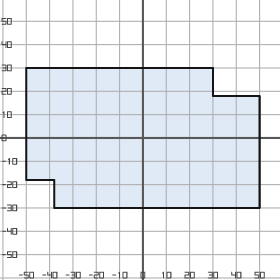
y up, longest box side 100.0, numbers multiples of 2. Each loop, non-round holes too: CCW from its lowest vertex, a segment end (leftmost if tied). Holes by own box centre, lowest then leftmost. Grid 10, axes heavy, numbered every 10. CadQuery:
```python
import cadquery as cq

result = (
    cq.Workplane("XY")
    .moveTo(-38.0, -30.0)
    .lineTo(50.0, -30.0)
    .lineTo(50.0, 18.0)
    .lineTo(30.0, 18.0)
    .lineTo(30.0, 30.0)
    .lineTo(-50.0, 30.0)
    .lineTo(-50.0, -18.0)
    .lineTo(-38.0, -18.0)
    .close()
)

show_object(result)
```